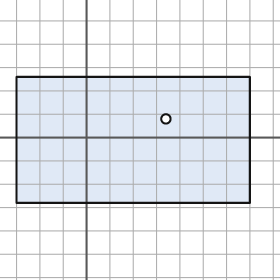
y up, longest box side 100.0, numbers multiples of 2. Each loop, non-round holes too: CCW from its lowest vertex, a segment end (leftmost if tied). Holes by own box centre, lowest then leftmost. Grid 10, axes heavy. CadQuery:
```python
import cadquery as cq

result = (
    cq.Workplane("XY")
    .moveTo(-30.0, -28.0)
    .lineTo(70.0, -28.0)
    .lineTo(70.0, 26.0)
    .lineTo(-30.0, 26.0)
    .close()
    .moveTo(34.0, 8.0)
    .circle(2.0)
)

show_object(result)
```